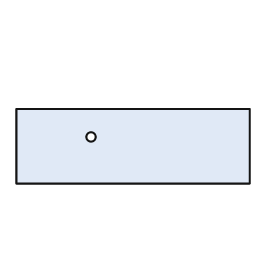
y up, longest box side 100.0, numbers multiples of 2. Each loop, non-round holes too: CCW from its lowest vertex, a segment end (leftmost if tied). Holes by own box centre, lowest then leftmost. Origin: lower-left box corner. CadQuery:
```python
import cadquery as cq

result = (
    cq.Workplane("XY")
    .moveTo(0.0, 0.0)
    .lineTo(100.0, 0.0)
    .lineTo(100.0, 32.0)
    .lineTo(0.0, 32.0)
    .close()
    .moveTo(32.0, 20.0)
    .circle(2.0)
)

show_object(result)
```